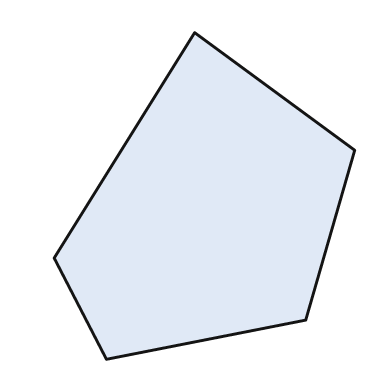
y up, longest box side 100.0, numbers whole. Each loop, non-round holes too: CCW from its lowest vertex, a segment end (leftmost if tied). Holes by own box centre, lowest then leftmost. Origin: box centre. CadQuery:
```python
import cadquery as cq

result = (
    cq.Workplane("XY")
    .moveTo(-30.0, -50.0)
    .lineTo(31.0, -38.0)
    .lineTo(46.0, 14.0)
    .lineTo(-3.0, 50.0)
    .lineTo(-46.0, -19.0)
    .close()
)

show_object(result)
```